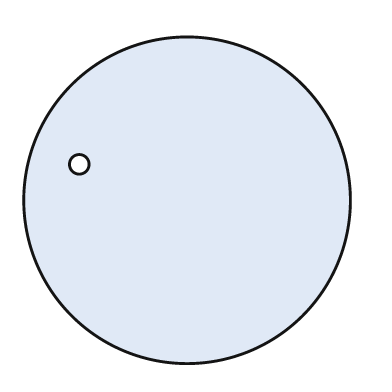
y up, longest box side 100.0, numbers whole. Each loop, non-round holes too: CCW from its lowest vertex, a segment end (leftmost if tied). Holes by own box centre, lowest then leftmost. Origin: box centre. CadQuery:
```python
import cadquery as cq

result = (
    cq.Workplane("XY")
    .moveTo(0.0, 0.0)
    .circle(50.0)
    .moveTo(-33.0, 11.0)
    .circle(3.0)
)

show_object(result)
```